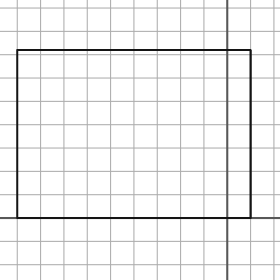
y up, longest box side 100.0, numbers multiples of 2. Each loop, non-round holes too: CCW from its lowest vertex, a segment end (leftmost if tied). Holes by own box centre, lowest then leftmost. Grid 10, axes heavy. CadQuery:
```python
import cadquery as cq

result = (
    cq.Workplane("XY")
    .moveTo(-90.0, 0.0)
    .lineTo(10.0, 0.0)
    .lineTo(10.0, 72.0)
    .lineTo(-90.0, 72.0)
    .close()
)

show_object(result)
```